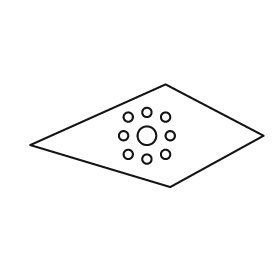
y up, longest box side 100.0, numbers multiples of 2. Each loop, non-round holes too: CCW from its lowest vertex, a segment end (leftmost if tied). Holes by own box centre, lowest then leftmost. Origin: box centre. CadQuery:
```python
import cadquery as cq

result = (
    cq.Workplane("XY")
    .moveTo(10.0, -22.0)
    .lineTo(50.0, 0.0)
    .lineTo(8.0, 22.0)
    .lineTo(-50.0, -4.0)
    .close()
    .moveTo(0.0, -10.0)
    .circle(2.0)
    .moveTo(-8.0, -8.0)
    .circle(2.0)
    .moveTo(8.0, -8.0)
    .circle(2.0)
    .moveTo(-10.0, 0.0)
    .circle(2.0)
    .moveTo(0.0, 0.0)
    .circle(4.0)
    .moveTo(10.0, 0.0)
    .circle(2.0)
    .moveTo(-8.0, 8.0)
    .circle(2.0)
    .moveTo(8.0, 8.0)
    .circle(2.0)
    .moveTo(0.0, 10.0)
    .circle(2.0)
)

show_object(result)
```